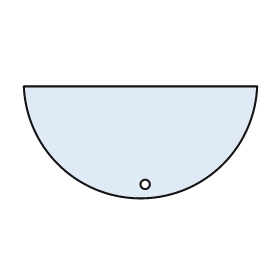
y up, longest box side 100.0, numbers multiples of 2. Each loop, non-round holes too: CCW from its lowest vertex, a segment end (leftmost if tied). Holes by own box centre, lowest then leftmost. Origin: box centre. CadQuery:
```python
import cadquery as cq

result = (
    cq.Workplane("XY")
    .moveTo(-50.0, 24.0)
    .threePointArc((0.0, -24.0), (50.0, 24.0))
    .close()
    .moveTo(2.0, -18.0)
    .circle(2.0)
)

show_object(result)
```